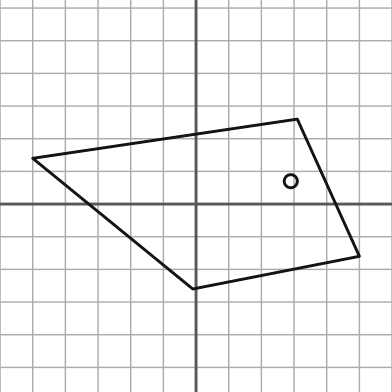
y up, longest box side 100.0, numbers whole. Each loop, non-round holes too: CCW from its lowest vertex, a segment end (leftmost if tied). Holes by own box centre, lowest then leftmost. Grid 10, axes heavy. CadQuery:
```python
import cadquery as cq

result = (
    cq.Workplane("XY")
    .moveTo(-1.0, -26.0)
    .lineTo(50.0, -16.0)
    .lineTo(31.0, 26.0)
    .lineTo(-50.0, 14.0)
    .close()
    .moveTo(29.0, 7.0)
    .circle(2.0)
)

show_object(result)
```